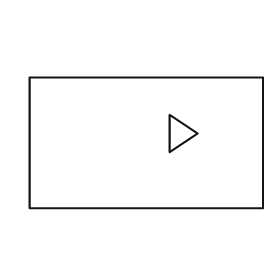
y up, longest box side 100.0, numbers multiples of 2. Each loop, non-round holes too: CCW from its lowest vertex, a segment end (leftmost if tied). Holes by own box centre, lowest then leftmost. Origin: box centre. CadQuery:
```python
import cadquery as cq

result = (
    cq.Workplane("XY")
    .moveTo(-50.0, -28.0)
    .lineTo(50.0, -28.0)
    .lineTo(50.0, 28.0)
    .lineTo(-50.0, 28.0)
    .close()
    .moveTo(10.0, -4.0)
    .lineTo(22.0, 4.0)
    .lineTo(10.0, 12.0)
    .close()
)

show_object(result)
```